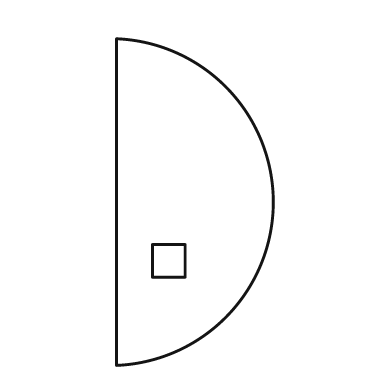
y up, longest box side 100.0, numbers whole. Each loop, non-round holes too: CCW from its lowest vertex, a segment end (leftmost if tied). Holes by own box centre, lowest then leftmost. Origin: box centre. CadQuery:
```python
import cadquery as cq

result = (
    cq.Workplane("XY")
    .moveTo(-24.0, -50.0)
    .threePointArc((24.0, 0.0), (-24.0, 50.0))
    .close()
    .moveTo(-13.0, -23.0)
    .lineTo(-3.0, -23.0)
    .lineTo(-3.0, -13.0)
    .lineTo(-13.0, -13.0)
    .close()
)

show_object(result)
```